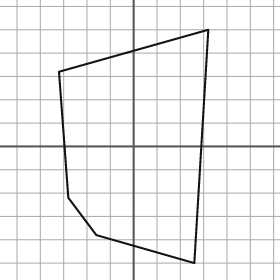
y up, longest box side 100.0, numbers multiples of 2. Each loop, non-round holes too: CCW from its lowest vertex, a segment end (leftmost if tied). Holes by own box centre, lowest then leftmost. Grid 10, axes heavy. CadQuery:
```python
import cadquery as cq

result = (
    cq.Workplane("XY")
    .moveTo(26.0, -50.0)
    .lineTo(32.0, 50.0)
    .lineTo(-32.0, 32.0)
    .lineTo(-28.0, -22.0)
    .lineTo(-16.0, -38.0)
    .close()
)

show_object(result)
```